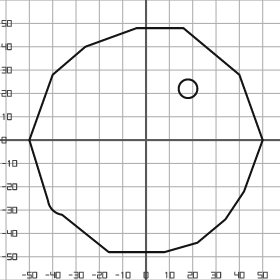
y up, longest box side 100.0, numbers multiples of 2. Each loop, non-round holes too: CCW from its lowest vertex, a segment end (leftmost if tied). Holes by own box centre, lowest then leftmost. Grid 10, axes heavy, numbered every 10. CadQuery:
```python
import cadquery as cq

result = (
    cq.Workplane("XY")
    .moveTo(-16.0, -48.0)
    .lineTo(8.0, -48.0)
    .lineTo(22.0, -44.0)
    .lineTo(34.0, -34.0)
    .lineTo(42.0, -22.0)
    .lineTo(50.0, 0.0)
    .lineTo(40.0, 28.0)
    .lineTo(16.0, 48.0)
    .lineTo(-4.0, 48.0)
    .lineTo(-26.0, 40.0)
    .lineTo(-40.0, 28.0)
    .lineTo(-50.0, 0.0)
    .lineTo(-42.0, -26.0)
    .threePointArc((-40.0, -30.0), (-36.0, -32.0))
    .close()
    .moveTo(18.0, 22.0)
    .circle(4.0)
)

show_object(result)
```